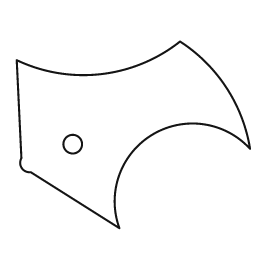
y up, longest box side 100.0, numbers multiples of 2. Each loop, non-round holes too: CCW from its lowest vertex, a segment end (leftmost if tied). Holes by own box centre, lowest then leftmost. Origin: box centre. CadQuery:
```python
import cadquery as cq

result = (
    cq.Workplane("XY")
    .moveTo(-6.0, -40.0)
    .threePointArc((8.0, 0.0), (50.0, -6.0))
    .threePointArc((40.0, 20.0), (20.0, 40.0))
    .threePointArc((-14.0, 26.0), (-50.0, 32.0))
    .lineTo(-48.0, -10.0)
    .threePointArc((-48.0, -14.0), (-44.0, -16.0))
    .close()
    .moveTo(-26.0, -4.0)
    .circle(4.0)
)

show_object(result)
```